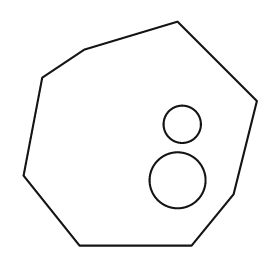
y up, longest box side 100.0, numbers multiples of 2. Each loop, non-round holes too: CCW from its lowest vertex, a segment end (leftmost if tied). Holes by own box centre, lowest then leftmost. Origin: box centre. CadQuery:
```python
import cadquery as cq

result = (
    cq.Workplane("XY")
    .moveTo(-26.0, -48.0)
    .lineTo(22.0, -48.0)
    .lineTo(40.0, -26.0)
    .lineTo(50.0, 14.0)
    .lineTo(16.0, 48.0)
    .lineTo(-24.0, 36.0)
    .lineTo(-42.0, 24.0)
    .lineTo(-50.0, -18.0)
    .close()
    .moveTo(16.0, -20.0)
    .circle(12.0)
    .moveTo(18.0, 4.0)
    .circle(8.0)
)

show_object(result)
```